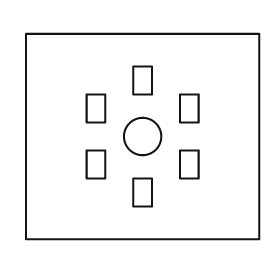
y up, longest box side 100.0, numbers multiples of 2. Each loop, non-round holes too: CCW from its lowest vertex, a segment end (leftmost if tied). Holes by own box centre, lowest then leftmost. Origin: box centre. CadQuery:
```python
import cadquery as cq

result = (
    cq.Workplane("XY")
    .moveTo(-50.0, -44.0)
    .lineTo(50.0, -44.0)
    .lineTo(50.0, 44.0)
    .lineTo(-50.0, 44.0)
    .close()
    .moveTo(-4.0, -30.0)
    .lineTo(4.0, -30.0)
    .lineTo(4.0, -18.0)
    .lineTo(-4.0, -18.0)
    .close()
    .moveTo(-24.0, -18.0)
    .lineTo(-16.0, -18.0)
    .lineTo(-16.0, -6.0)
    .lineTo(-24.0, -6.0)
    .close()
    .moveTo(16.0, -18.0)
    .lineTo(24.0, -18.0)
    .lineTo(24.0, -6.0)
    .lineTo(16.0, -6.0)
    .close()
    .moveTo(0.0, 0.0)
    .circle(8.0)
    .moveTo(-24.0, 6.0)
    .lineTo(-16.0, 6.0)
    .lineTo(-16.0, 18.0)
    .lineTo(-24.0, 18.0)
    .close()
    .moveTo(16.0, 6.0)
    .lineTo(24.0, 6.0)
    .lineTo(24.0, 18.0)
    .lineTo(16.0, 18.0)
    .close()
    .moveTo(-4.0, 18.0)
    .lineTo(4.0, 18.0)
    .lineTo(4.0, 30.0)
    .lineTo(-4.0, 30.0)
    .close()
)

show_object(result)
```